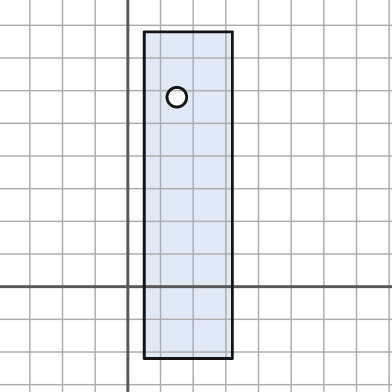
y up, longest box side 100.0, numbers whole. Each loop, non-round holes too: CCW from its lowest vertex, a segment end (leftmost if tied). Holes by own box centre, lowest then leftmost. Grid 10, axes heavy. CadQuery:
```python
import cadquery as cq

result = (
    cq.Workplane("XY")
    .moveTo(5.0, -22.0)
    .lineTo(32.0, -22.0)
    .lineTo(32.0, 78.0)
    .lineTo(5.0, 78.0)
    .close()
    .moveTo(15.0, 58.0)
    .circle(3.0)
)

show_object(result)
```